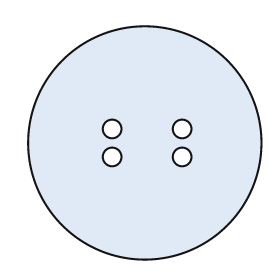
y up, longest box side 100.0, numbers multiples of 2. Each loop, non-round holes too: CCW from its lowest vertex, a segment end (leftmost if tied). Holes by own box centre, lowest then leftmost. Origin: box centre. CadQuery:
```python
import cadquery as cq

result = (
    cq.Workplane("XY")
    .moveTo(0.0, 0.0)
    .circle(50.0)
    .moveTo(-14.0, -6.0)
    .circle(4.0)
    .moveTo(16.0, -6.0)
    .circle(4.0)
    .moveTo(-14.0, 6.0)
    .circle(4.0)
    .moveTo(16.0, 6.0)
    .circle(4.0)
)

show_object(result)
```